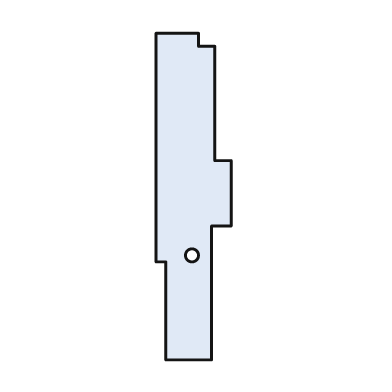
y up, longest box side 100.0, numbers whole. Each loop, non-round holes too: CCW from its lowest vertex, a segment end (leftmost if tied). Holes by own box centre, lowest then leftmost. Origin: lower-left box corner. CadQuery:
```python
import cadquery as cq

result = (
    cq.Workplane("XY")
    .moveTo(3.0, 0.0)
    .lineTo(17.0, 0.0)
    .lineTo(17.0, 41.0)
    .lineTo(23.0, 41.0)
    .lineTo(23.0, 61.0)
    .lineTo(18.0, 61.0)
    .lineTo(18.0, 96.0)
    .lineTo(13.0, 96.0)
    .lineTo(13.0, 100.0)
    .lineTo(0.0, 100.0)
    .lineTo(0.0, 30.0)
    .lineTo(3.0, 30.0)
    .close()
    .moveTo(11.0, 32.0)
    .circle(2.0)
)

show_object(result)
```